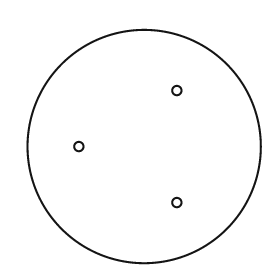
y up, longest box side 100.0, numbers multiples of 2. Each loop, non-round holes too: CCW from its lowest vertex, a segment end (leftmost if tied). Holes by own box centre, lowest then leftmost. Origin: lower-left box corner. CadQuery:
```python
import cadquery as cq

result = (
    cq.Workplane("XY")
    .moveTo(50.0, 50.0)
    .circle(50.0)
    .moveTo(64.0, 26.0)
    .circle(2.0)
    .moveTo(22.0, 50.0)
    .circle(2.0)
    .moveTo(64.0, 74.0)
    .circle(2.0)
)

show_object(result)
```